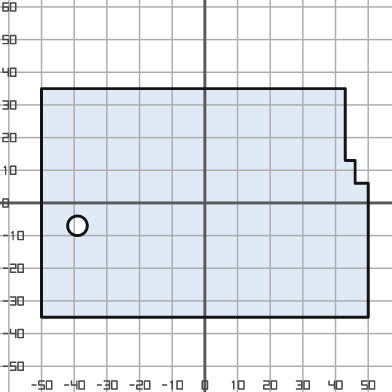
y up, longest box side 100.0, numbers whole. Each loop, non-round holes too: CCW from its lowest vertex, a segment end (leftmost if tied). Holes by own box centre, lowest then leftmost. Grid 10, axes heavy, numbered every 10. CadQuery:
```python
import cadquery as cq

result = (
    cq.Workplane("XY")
    .moveTo(-50.0, -35.0)
    .lineTo(50.0, -35.0)
    .lineTo(50.0, 6.0)
    .lineTo(46.0, 6.0)
    .lineTo(46.0, 13.0)
    .lineTo(43.0, 13.0)
    .lineTo(43.0, 35.0)
    .lineTo(-50.0, 35.0)
    .close()
    .moveTo(-39.0, -7.0)
    .circle(3.0)
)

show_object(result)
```